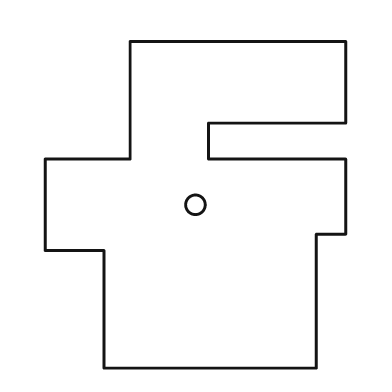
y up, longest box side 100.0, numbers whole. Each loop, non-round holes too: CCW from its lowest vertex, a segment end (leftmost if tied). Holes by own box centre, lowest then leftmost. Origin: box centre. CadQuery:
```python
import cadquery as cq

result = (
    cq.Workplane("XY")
    .moveTo(-28.0, -50.0)
    .lineTo(37.0, -50.0)
    .lineTo(37.0, -9.0)
    .lineTo(46.0, -9.0)
    .lineTo(46.0, 14.0)
    .lineTo(4.0, 14.0)
    .lineTo(4.0, 25.0)
    .lineTo(46.0, 25.0)
    .lineTo(46.0, 50.0)
    .lineTo(-20.0, 50.0)
    .lineTo(-20.0, 14.0)
    .lineTo(-46.0, 14.0)
    .lineTo(-46.0, -14.0)
    .lineTo(-28.0, -14.0)
    .close()
    .moveTo(0.0, 0.0)
    .circle(3.0)
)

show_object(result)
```